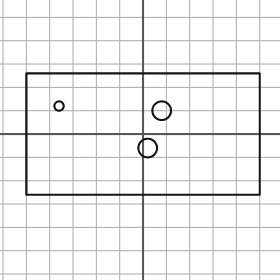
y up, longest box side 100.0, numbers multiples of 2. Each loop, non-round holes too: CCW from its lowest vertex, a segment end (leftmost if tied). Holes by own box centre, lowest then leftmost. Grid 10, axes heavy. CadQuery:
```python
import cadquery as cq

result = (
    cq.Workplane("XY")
    .moveTo(-50.0, -26.0)
    .lineTo(50.0, -26.0)
    .lineTo(50.0, 26.0)
    .lineTo(-50.0, 26.0)
    .close()
    .moveTo(2.0, -6.0)
    .circle(4.0)
    .moveTo(8.0, 10.0)
    .circle(4.0)
    .moveTo(-36.0, 12.0)
    .circle(2.0)
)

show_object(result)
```